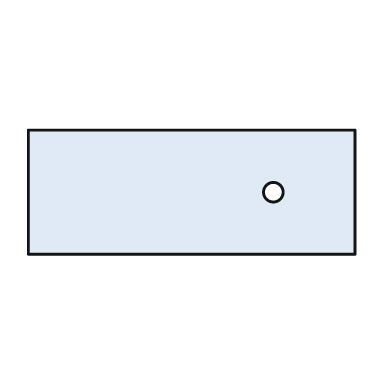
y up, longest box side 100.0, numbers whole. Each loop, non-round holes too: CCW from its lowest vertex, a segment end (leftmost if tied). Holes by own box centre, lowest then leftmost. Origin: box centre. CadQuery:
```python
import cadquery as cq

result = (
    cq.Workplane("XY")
    .moveTo(-50.0, -19.0)
    .lineTo(50.0, -19.0)
    .lineTo(50.0, 19.0)
    .lineTo(-50.0, 19.0)
    .close()
    .moveTo(25.0, 0.0)
    .circle(3.0)
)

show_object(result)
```